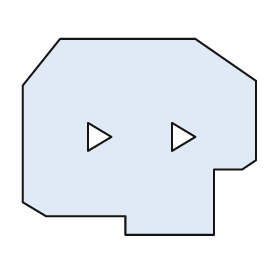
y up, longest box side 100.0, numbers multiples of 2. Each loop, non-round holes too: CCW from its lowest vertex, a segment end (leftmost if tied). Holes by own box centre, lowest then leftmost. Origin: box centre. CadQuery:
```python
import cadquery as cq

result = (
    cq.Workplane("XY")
    .moveTo(-6.0, -42.0)
    .lineTo(32.0, -42.0)
    .lineTo(32.0, -14.0)
    .lineTo(44.0, -14.0)
    .lineTo(50.0, -10.0)
    .lineTo(50.0, 24.0)
    .lineTo(24.0, 42.0)
    .lineTo(-34.0, 42.0)
    .lineTo(-50.0, 22.0)
    .lineTo(-50.0, -28.0)
    .lineTo(-40.0, -34.0)
    .lineTo(-6.0, -34.0)
    .close()
    .moveTo(-22.0, -6.0)
    .lineTo(-12.0, 0.0)
    .lineTo(-22.0, 6.0)
    .close()
    .moveTo(14.0, -6.0)
    .lineTo(24.0, 0.0)
    .lineTo(14.0, 6.0)
    .close()
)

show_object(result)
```